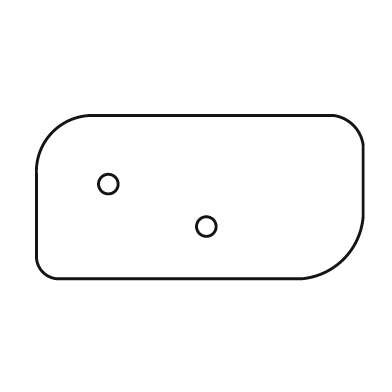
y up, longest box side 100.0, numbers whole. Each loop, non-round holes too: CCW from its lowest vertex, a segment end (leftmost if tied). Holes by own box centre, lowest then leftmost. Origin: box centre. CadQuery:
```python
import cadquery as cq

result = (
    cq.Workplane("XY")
    .moveTo(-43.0, -25.0)
    .lineTo(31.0, -25.0)
    .threePointArc((44.0, -19.0), (50.0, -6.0))
    .lineTo(50.0, 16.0)
    .threePointArc((47.0, 22.0), (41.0, 25.0))
    .lineTo(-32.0, 25.0)
    .threePointArc((-45.0, 20.0), (-50.0, 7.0))
    .lineTo(-50.0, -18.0)
    .threePointArc((-48.0, -23.0), (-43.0, -25.0))
    .close()
    .moveTo(2.0, -9.0)
    .circle(3.0)
    .moveTo(-28.0, 4.0)
    .circle(3.0)
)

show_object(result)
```